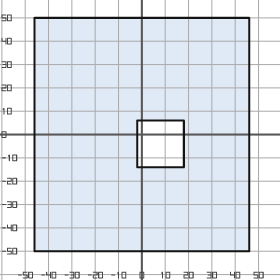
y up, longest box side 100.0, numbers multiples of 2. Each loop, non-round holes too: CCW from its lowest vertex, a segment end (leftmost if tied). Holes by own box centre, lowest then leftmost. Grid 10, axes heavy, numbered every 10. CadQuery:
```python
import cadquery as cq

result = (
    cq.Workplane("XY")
    .moveTo(-46.0, -50.0)
    .lineTo(46.0, -50.0)
    .lineTo(46.0, 50.0)
    .lineTo(-46.0, 50.0)
    .close()
    .moveTo(-2.0, -14.0)
    .lineTo(18.0, -14.0)
    .lineTo(18.0, 6.0)
    .lineTo(-2.0, 6.0)
    .close()
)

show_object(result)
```